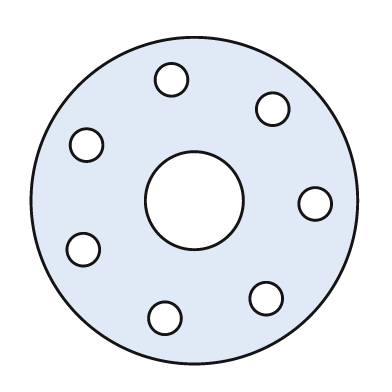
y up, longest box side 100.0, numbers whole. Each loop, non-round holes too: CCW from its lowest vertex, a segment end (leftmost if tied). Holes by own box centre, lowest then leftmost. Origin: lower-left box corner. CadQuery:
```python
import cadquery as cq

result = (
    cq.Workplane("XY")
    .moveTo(50.0, 50.0)
    .circle(50.0)
    .moveTo(41.0, 14.0)
    .circle(5.0)
    .moveTo(72.0, 20.0)
    .circle(5.0)
    .moveTo(16.0, 35.0)
    .circle(5.0)
    .moveTo(87.0, 49.0)
    .circle(5.0)
    .moveTo(50.0, 50.0)
    .circle(15.0)
    .moveTo(17.0, 67.0)
    .circle(5.0)
    .moveTo(74.0, 78.0)
    .circle(5.0)
    .moveTo(43.0, 87.0)
    .circle(5.0)
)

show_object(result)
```